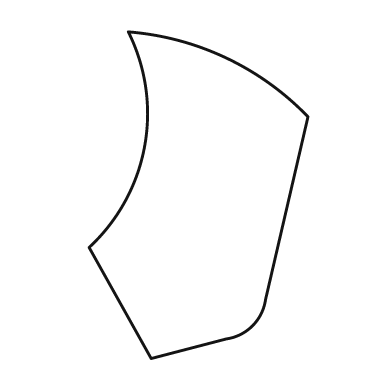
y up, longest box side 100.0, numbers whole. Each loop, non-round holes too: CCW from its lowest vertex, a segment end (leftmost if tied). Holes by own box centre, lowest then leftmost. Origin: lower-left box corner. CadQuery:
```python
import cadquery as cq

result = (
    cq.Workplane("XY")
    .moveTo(19.0, 0.0)
    .lineTo(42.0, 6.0)
    .threePointArc((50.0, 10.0), (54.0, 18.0))
    .lineTo(67.0, 74.0)
    .threePointArc((42.0, 92.0), (12.0, 100.0))
    .threePointArc((17.0, 65.0), (0.0, 34.0))
    .close()
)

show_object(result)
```